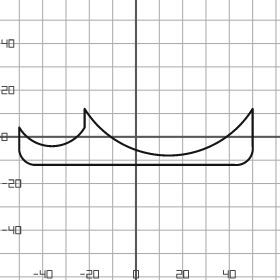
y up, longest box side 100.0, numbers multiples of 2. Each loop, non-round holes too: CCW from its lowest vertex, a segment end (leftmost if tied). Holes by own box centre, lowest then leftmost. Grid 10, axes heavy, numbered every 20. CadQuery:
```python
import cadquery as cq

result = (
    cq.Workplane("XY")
    .moveTo(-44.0, -12.0)
    .lineTo(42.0, -12.0)
    .threePointArc((48.0, -10.0), (50.0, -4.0))
    .lineTo(50.0, 12.0)
    .threePointArc((14.0, -8.0), (-22.0, 12.0))
    .lineTo(-22.0, 4.0)
    .threePointArc((-36.0, -4.0), (-50.0, 4.0))
    .lineTo(-50.0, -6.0)
    .threePointArc((-48.0, -10.0), (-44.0, -12.0))
    .close()
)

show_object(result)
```